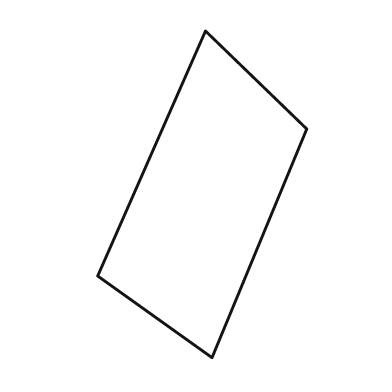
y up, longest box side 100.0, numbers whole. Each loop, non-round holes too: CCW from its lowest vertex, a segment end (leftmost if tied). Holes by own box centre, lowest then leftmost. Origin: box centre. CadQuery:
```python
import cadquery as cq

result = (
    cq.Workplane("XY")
    .moveTo(3.0, -50.0)
    .lineTo(32.0, 20.0)
    .lineTo(1.0, 50.0)
    .lineTo(-32.0, -25.0)
    .close()
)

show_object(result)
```